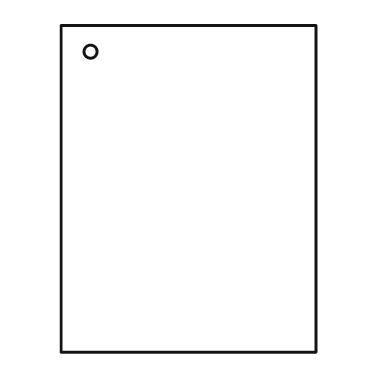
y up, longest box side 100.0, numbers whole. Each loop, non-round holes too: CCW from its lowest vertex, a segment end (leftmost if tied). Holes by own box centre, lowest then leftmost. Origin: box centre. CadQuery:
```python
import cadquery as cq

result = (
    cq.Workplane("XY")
    .moveTo(-39.0, -50.0)
    .lineTo(39.0, -50.0)
    .lineTo(39.0, 50.0)
    .lineTo(-39.0, 50.0)
    .close()
    .moveTo(-30.0, 42.0)
    .circle(2.0)
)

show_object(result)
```